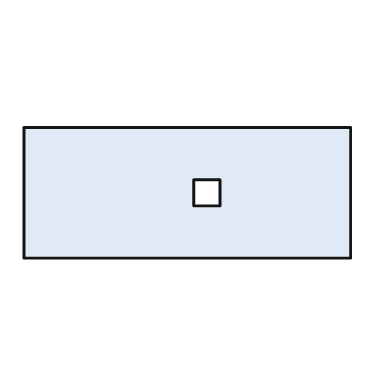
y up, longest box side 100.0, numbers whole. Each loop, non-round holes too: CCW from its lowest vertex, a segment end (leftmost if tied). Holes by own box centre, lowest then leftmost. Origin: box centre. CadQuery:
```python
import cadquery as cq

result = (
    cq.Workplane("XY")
    .moveTo(-50.0, -20.0)
    .lineTo(50.0, -20.0)
    .lineTo(50.0, 20.0)
    .lineTo(-50.0, 20.0)
    .close()
    .moveTo(2.0, -4.0)
    .lineTo(10.0, -4.0)
    .lineTo(10.0, 4.0)
    .lineTo(2.0, 4.0)
    .close()
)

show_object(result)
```